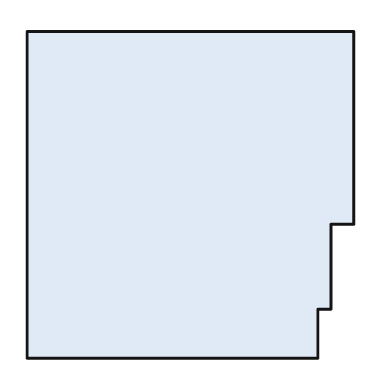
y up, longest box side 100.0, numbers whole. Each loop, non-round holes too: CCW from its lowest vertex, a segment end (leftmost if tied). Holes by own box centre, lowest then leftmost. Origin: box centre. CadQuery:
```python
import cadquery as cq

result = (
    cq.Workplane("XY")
    .moveTo(-50.0, -50.0)
    .lineTo(39.0, -50.0)
    .lineTo(39.0, -35.0)
    .lineTo(43.0, -35.0)
    .lineTo(43.0, -9.0)
    .lineTo(50.0, -9.0)
    .lineTo(50.0, 50.0)
    .lineTo(-50.0, 50.0)
    .close()
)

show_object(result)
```